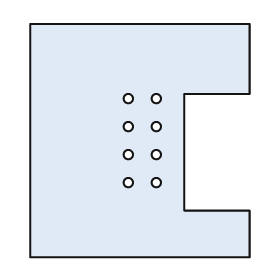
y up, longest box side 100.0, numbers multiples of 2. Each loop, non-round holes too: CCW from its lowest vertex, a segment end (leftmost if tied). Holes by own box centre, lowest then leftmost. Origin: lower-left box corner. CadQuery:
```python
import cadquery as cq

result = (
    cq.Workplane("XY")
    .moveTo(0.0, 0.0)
    .lineTo(94.0, 0.0)
    .lineTo(94.0, 20.0)
    .lineTo(66.0, 20.0)
    .lineTo(66.0, 70.0)
    .lineTo(94.0, 70.0)
    .lineTo(94.0, 100.0)
    .lineTo(0.0, 100.0)
    .close()
    .moveTo(42.0, 32.0)
    .circle(2.0)
    .moveTo(54.0, 32.0)
    .circle(2.0)
    .moveTo(42.0, 44.0)
    .circle(2.0)
    .moveTo(54.0, 44.0)
    .circle(2.0)
    .moveTo(42.0, 56.0)
    .circle(2.0)
    .moveTo(54.0, 56.0)
    .circle(2.0)
    .moveTo(42.0, 68.0)
    .circle(2.0)
    .moveTo(54.0, 68.0)
    .circle(2.0)
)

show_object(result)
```